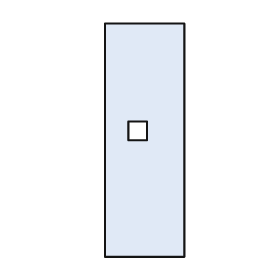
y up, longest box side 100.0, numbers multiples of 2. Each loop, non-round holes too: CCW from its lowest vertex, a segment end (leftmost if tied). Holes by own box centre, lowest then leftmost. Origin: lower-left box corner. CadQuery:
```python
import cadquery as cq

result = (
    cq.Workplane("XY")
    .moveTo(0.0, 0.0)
    .lineTo(34.0, 0.0)
    .lineTo(34.0, 100.0)
    .lineTo(0.0, 100.0)
    .close()
    .moveTo(10.0, 50.0)
    .lineTo(18.0, 50.0)
    .lineTo(18.0, 58.0)
    .lineTo(10.0, 58.0)
    .close()
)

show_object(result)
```